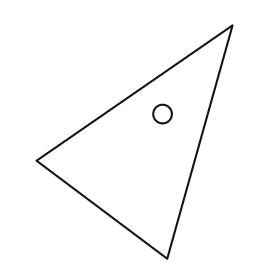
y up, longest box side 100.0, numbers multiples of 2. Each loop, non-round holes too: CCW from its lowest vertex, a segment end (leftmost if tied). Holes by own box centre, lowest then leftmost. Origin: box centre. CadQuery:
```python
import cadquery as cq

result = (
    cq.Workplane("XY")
    .moveTo(14.0, -50.0)
    .lineTo(42.0, 50.0)
    .lineTo(-42.0, -8.0)
    .close()
    .moveTo(12.0, 12.0)
    .circle(4.0)
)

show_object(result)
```